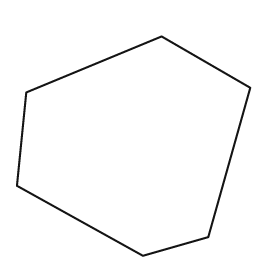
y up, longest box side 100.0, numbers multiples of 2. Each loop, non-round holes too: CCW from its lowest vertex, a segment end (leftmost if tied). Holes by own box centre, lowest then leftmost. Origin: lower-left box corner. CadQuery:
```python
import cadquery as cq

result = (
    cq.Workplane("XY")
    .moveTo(54.0, 0.0)
    .lineTo(82.0, 8.0)
    .lineTo(100.0, 72.0)
    .lineTo(62.0, 94.0)
    .lineTo(4.0, 70.0)
    .lineTo(0.0, 30.0)
    .close()
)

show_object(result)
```